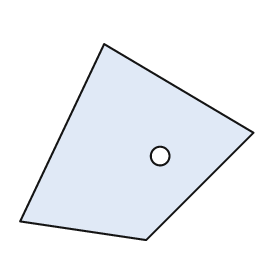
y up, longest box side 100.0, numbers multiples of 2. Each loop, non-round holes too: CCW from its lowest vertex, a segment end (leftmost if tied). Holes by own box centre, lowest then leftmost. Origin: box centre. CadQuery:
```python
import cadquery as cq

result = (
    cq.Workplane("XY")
    .moveTo(4.0, -42.0)
    .lineTo(50.0, 4.0)
    .lineTo(-14.0, 42.0)
    .lineTo(-50.0, -34.0)
    .close()
    .moveTo(10.0, -6.0)
    .circle(4.0)
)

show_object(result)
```